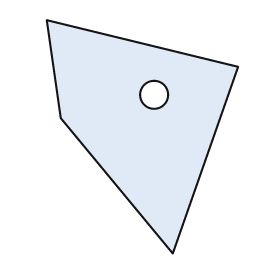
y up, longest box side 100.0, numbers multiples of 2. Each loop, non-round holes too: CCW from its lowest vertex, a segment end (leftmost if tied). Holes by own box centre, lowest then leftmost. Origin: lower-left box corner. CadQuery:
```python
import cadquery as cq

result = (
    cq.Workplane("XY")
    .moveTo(54.0, 0.0)
    .lineTo(82.0, 80.0)
    .lineTo(0.0, 100.0)
    .lineTo(6.0, 58.0)
    .close()
    .moveTo(46.0, 68.0)
    .circle(6.0)
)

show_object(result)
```